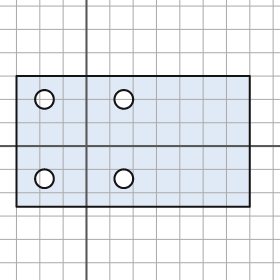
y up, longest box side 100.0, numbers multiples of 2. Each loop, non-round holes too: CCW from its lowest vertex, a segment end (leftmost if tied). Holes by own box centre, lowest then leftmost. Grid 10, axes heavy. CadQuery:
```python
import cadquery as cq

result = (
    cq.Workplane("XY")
    .moveTo(-30.0, -26.0)
    .lineTo(70.0, -26.0)
    .lineTo(70.0, 30.0)
    .lineTo(-30.0, 30.0)
    .close()
    .moveTo(-18.0, -14.0)
    .circle(4.0)
    .moveTo(16.0, -14.0)
    .circle(4.0)
    .moveTo(-18.0, 20.0)
    .circle(4.0)
    .moveTo(16.0, 20.0)
    .circle(4.0)
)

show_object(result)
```